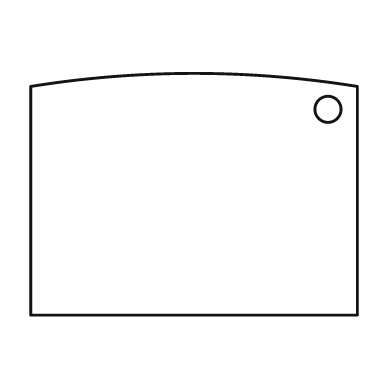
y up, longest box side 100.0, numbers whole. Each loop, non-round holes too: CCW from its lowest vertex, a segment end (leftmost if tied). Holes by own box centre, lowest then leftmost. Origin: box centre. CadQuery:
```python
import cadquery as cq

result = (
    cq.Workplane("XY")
    .moveTo(-50.0, -37.0)
    .lineTo(50.0, -37.0)
    .lineTo(50.0, 33.0)
    .threePointArc((0.0, 37.0), (-50.0, 33.0))
    .close()
    .moveTo(41.0, 26.0)
    .circle(4.0)
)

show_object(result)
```